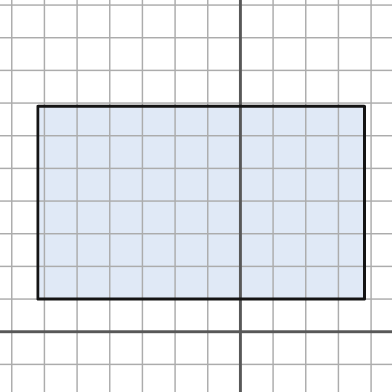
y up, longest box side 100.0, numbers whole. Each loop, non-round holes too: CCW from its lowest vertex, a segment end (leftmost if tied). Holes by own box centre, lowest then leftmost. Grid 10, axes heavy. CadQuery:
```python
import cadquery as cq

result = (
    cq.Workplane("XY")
    .moveTo(-62.0, 10.0)
    .lineTo(38.0, 10.0)
    .lineTo(38.0, 69.0)
    .lineTo(-62.0, 69.0)
    .close()
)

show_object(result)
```